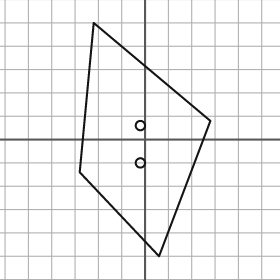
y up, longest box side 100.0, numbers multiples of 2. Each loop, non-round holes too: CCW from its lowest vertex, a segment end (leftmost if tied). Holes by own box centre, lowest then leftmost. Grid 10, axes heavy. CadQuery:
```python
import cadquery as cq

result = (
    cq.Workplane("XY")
    .moveTo(6.0, -50.0)
    .lineTo(28.0, 8.0)
    .lineTo(-22.0, 50.0)
    .lineTo(-28.0, -14.0)
    .close()
    .moveTo(-2.0, -10.0)
    .circle(2.0)
    .moveTo(-2.0, 6.0)
    .circle(2.0)
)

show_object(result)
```